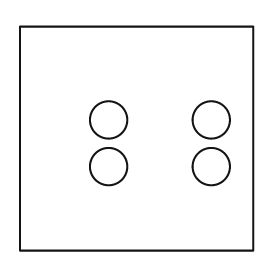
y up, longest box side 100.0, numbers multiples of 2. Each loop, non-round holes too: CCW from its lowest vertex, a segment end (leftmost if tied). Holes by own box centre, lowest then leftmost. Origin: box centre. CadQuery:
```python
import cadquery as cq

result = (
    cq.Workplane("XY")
    .moveTo(-50.0, -48.0)
    .lineTo(50.0, -48.0)
    .lineTo(50.0, 48.0)
    .lineTo(-50.0, 48.0)
    .close()
    .moveTo(-12.0, -12.0)
    .circle(8.0)
    .moveTo(32.0, -12.0)
    .circle(8.0)
    .moveTo(-12.0, 8.0)
    .circle(8.0)
    .moveTo(32.0, 8.0)
    .circle(8.0)
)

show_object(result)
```